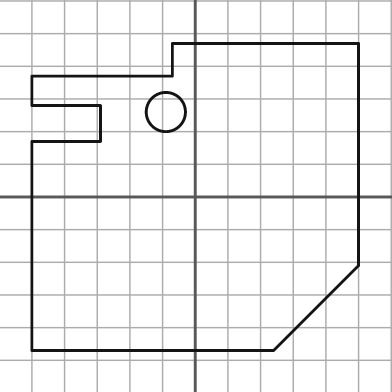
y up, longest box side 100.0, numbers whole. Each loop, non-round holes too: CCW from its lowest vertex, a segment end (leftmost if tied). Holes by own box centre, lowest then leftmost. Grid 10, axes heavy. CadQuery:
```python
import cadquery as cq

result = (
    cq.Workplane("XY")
    .moveTo(-50.0, -47.0)
    .lineTo(24.0, -47.0)
    .lineTo(50.0, -21.0)
    .lineTo(50.0, 47.0)
    .lineTo(-7.0, 47.0)
    .lineTo(-7.0, 37.0)
    .lineTo(-50.0, 37.0)
    .lineTo(-50.0, 28.0)
    .lineTo(-29.0, 28.0)
    .lineTo(-29.0, 17.0)
    .lineTo(-50.0, 17.0)
    .close()
    .moveTo(-9.0, 26.0)
    .circle(6.0)
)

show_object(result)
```